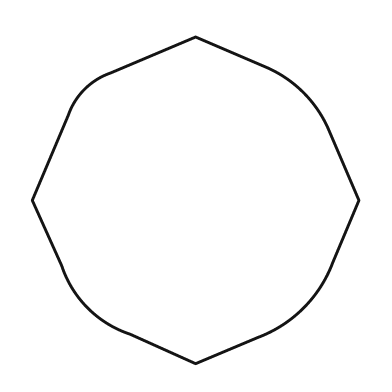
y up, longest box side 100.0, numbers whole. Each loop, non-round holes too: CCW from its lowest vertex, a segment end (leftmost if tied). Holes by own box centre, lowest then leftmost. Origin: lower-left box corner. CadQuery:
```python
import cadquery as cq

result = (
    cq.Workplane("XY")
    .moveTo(50.0, 0.0)
    .lineTo(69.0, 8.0)
    .threePointArc((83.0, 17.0), (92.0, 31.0))
    .lineTo(100.0, 50.0)
    .lineTo(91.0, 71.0)
    .threePointArc((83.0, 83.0), (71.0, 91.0))
    .lineTo(50.0, 100.0)
    .lineTo(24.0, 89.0)
    .threePointArc((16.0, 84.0), (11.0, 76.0))
    .lineTo(0.0, 50.0)
    .lineTo(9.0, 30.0)
    .threePointArc((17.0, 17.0), (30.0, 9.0))
    .close()
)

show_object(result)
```